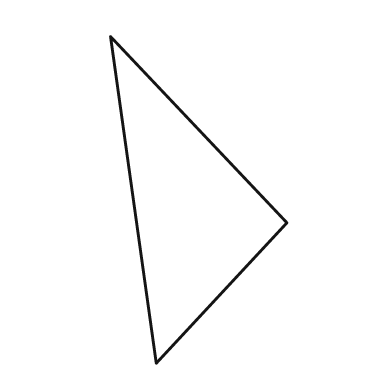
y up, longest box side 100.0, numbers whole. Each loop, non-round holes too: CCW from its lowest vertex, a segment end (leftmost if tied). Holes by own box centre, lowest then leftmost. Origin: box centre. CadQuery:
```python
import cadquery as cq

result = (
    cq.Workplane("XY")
    .moveTo(-13.0, -50.0)
    .lineTo(27.0, -7.0)
    .lineTo(-27.0, 50.0)
    .close()
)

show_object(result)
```